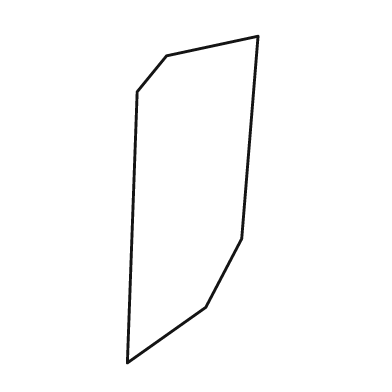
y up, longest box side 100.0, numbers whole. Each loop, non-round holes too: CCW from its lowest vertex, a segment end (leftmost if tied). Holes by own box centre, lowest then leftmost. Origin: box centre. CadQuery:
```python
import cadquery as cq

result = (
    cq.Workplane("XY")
    .moveTo(-20.0, -50.0)
    .lineTo(4.0, -33.0)
    .lineTo(15.0, -12.0)
    .lineTo(20.0, 50.0)
    .lineTo(-8.0, 44.0)
    .lineTo(-17.0, 33.0)
    .close()
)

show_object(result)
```